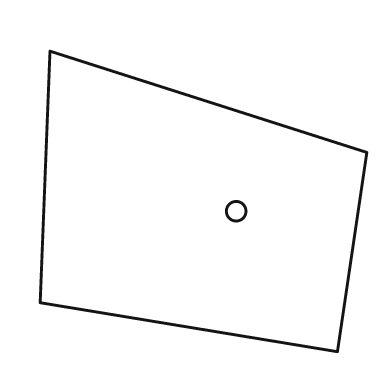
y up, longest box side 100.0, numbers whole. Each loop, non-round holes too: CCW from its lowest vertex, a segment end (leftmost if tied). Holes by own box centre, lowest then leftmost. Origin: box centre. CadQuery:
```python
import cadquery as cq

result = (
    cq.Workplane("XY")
    .moveTo(41.0, -46.0)
    .lineTo(50.0, 15.0)
    .lineTo(-47.0, 46.0)
    .lineTo(-50.0, -31.0)
    .close()
    .moveTo(10.0, -3.0)
    .circle(3.0)
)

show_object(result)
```